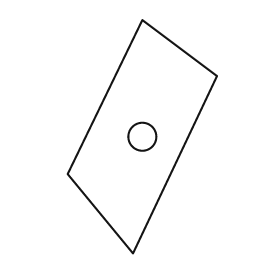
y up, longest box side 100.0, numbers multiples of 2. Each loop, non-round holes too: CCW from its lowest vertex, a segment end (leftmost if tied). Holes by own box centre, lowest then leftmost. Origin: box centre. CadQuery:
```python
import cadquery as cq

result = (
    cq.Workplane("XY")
    .moveTo(-4.0, -50.0)
    .lineTo(32.0, 26.0)
    .lineTo(0.0, 50.0)
    .lineTo(-32.0, -16.0)
    .close()
    .moveTo(0.0, 0.0)
    .circle(6.0)
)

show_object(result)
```